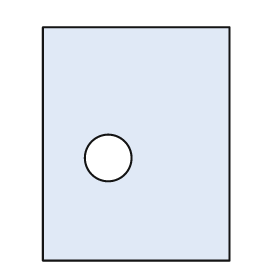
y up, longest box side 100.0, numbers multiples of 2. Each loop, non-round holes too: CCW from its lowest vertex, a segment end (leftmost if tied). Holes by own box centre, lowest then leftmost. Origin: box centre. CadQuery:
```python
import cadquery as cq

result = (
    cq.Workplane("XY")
    .moveTo(-40.0, -50.0)
    .lineTo(40.0, -50.0)
    .lineTo(40.0, 50.0)
    .lineTo(-40.0, 50.0)
    .close()
    .moveTo(-12.0, -6.0)
    .circle(10.0)
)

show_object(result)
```